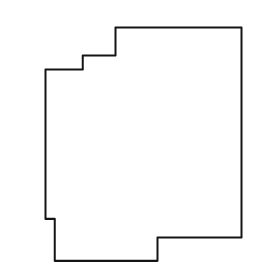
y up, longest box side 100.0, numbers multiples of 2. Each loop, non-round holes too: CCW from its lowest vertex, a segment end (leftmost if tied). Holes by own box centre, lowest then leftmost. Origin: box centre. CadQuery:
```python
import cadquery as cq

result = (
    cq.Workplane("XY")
    .moveTo(-38.0, -50.0)
    .lineTo(6.0, -50.0)
    .lineTo(6.0, -40.0)
    .lineTo(42.0, -40.0)
    .lineTo(42.0, 50.0)
    .lineTo(-12.0, 50.0)
    .lineTo(-12.0, 38.0)
    .lineTo(-26.0, 38.0)
    .lineTo(-26.0, 32.0)
    .lineTo(-42.0, 32.0)
    .lineTo(-42.0, -32.0)
    .lineTo(-38.0, -32.0)
    .close()
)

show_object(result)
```